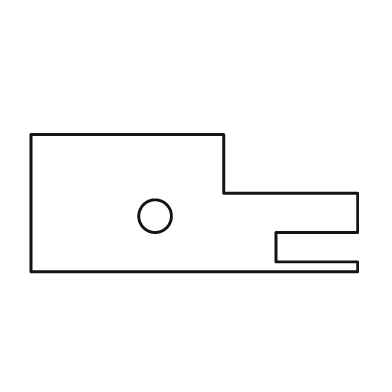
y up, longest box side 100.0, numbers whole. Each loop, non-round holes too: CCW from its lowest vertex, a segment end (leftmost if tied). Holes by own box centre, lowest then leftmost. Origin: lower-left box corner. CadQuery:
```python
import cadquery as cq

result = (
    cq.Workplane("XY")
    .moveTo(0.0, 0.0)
    .lineTo(100.0, 0.0)
    .lineTo(100.0, 3.0)
    .lineTo(75.0, 3.0)
    .lineTo(75.0, 12.0)
    .lineTo(100.0, 12.0)
    .lineTo(100.0, 24.0)
    .lineTo(59.0, 24.0)
    .lineTo(59.0, 42.0)
    .lineTo(0.0, 42.0)
    .close()
    .moveTo(38.0, 17.0)
    .circle(5.0)
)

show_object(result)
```